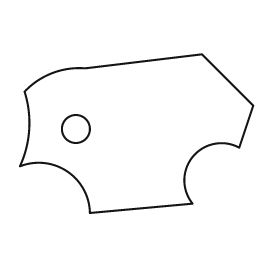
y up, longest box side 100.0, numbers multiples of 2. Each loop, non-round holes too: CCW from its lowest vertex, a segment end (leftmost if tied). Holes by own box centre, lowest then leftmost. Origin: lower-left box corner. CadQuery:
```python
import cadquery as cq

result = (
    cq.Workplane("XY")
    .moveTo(30.0, 0.0)
    .lineTo(74.0, 4.0)
    .threePointArc((74.0, 24.0), (94.0, 28.0))
    .lineTo(100.0, 46.0)
    .lineTo(78.0, 68.0)
    .lineTo(28.0, 62.0)
    .threePointArc((14.0, 60.0), (2.0, 52.0))
    .threePointArc((4.0, 36.0), (0.0, 20.0))
    .threePointArc((20.0, 18.0), (30.0, 0.0))
    .close()
    .moveTo(24.0, 36.0)
    .circle(6.0)
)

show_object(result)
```